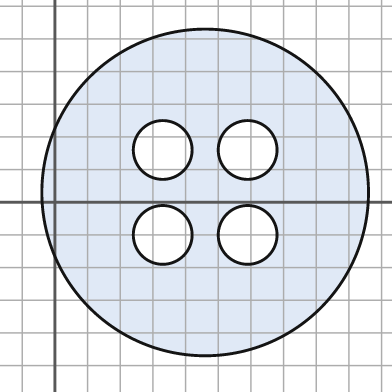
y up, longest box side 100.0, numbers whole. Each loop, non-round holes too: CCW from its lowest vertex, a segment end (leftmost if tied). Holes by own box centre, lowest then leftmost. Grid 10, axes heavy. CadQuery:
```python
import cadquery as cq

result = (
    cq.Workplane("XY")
    .moveTo(46.0, 3.0)
    .circle(50.0)
    .moveTo(33.0, -10.0)
    .circle(9.0)
    .moveTo(59.0, -10.0)
    .circle(9.0)
    .moveTo(33.0, 16.0)
    .circle(9.0)
    .moveTo(59.0, 16.0)
    .circle(9.0)
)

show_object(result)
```